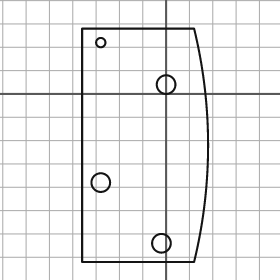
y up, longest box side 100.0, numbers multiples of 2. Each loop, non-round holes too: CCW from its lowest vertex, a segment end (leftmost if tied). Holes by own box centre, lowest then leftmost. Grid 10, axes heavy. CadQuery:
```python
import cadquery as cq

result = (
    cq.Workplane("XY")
    .moveTo(-36.0, -72.0)
    .lineTo(12.0, -72.0)
    .threePointArc((18.0, -22.0), (12.0, 28.0))
    .lineTo(-36.0, 28.0)
    .close()
    .moveTo(-2.0, -64.0)
    .circle(4.0)
    .moveTo(-28.0, -38.0)
    .circle(4.0)
    .moveTo(0.0, 4.0)
    .circle(4.0)
    .moveTo(-28.0, 22.0)
    .circle(2.0)
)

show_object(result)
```